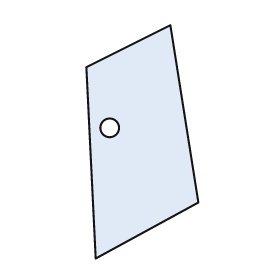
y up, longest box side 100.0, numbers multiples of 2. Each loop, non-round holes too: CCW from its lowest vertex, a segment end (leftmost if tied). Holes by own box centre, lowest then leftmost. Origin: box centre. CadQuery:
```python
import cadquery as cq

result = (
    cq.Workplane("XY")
    .moveTo(-20.0, -50.0)
    .lineTo(24.0, -26.0)
    .lineTo(12.0, 50.0)
    .lineTo(-24.0, 32.0)
    .close()
    .moveTo(-14.0, 6.0)
    .circle(4.0)
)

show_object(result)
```